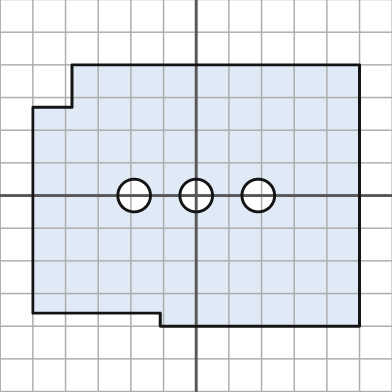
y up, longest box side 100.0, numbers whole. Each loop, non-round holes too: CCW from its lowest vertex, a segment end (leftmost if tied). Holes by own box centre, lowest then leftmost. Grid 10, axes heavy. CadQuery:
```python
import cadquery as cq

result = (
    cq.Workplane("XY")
    .moveTo(-11.0, -40.0)
    .lineTo(50.0, -40.0)
    .lineTo(50.0, 40.0)
    .lineTo(-38.0, 40.0)
    .lineTo(-38.0, 27.0)
    .lineTo(-50.0, 27.0)
    .lineTo(-50.0, -36.0)
    .lineTo(-11.0, -36.0)
    .close()
    .moveTo(-19.0, 0.0)
    .circle(5.0)
    .moveTo(0.0, 0.0)
    .circle(5.0)
    .moveTo(19.0, 0.0)
    .circle(5.0)
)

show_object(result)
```